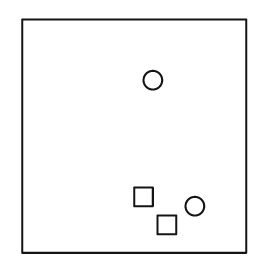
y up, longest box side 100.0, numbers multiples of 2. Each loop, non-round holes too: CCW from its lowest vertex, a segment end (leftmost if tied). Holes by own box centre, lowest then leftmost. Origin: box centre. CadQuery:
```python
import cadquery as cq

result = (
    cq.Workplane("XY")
    .moveTo(-48.0, -50.0)
    .lineTo(48.0, -50.0)
    .lineTo(48.0, 50.0)
    .lineTo(-48.0, 50.0)
    .close()
    .moveTo(10.0, -42.0)
    .lineTo(18.0, -42.0)
    .lineTo(18.0, -34.0)
    .lineTo(10.0, -34.0)
    .close()
    .moveTo(26.0, -30.0)
    .circle(4.0)
    .moveTo(0.0, -30.0)
    .lineTo(8.0, -30.0)
    .lineTo(8.0, -22.0)
    .lineTo(0.0, -22.0)
    .close()
    .moveTo(8.0, 24.0)
    .circle(4.0)
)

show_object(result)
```